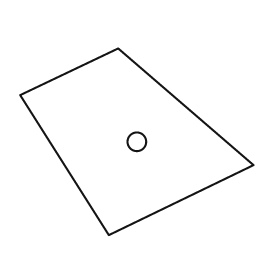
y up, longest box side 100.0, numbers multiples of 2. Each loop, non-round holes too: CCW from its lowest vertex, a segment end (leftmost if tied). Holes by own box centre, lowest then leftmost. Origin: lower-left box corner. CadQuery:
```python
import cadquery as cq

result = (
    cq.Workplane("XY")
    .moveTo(38.0, 0.0)
    .lineTo(100.0, 30.0)
    .lineTo(42.0, 80.0)
    .lineTo(0.0, 60.0)
    .close()
    .moveTo(50.0, 40.0)
    .circle(4.0)
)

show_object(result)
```